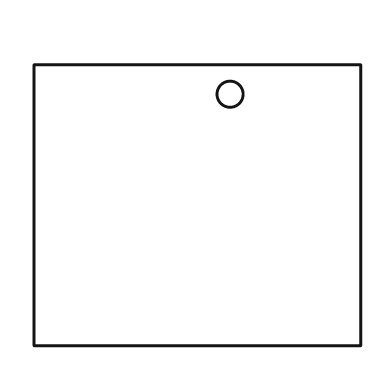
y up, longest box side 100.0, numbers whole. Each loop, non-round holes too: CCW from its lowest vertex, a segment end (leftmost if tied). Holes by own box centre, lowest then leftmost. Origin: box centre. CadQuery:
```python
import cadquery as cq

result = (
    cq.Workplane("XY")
    .moveTo(-50.0, -43.0)
    .lineTo(50.0, -43.0)
    .lineTo(50.0, 43.0)
    .lineTo(-50.0, 43.0)
    .close()
    .moveTo(10.0, 34.0)
    .circle(4.0)
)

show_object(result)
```